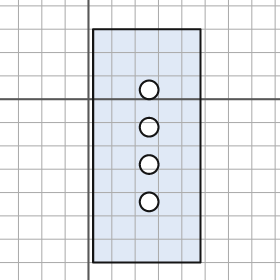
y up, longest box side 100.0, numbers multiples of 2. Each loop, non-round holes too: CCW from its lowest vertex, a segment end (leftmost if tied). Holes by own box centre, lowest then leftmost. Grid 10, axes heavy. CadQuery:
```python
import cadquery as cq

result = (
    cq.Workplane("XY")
    .moveTo(2.0, -70.0)
    .lineTo(48.0, -70.0)
    .lineTo(48.0, 30.0)
    .lineTo(2.0, 30.0)
    .close()
    .moveTo(26.0, -44.0)
    .circle(4.0)
    .moveTo(26.0, -28.0)
    .circle(4.0)
    .moveTo(26.0, -12.0)
    .circle(4.0)
    .moveTo(26.0, 4.0)
    .circle(4.0)
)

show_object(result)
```